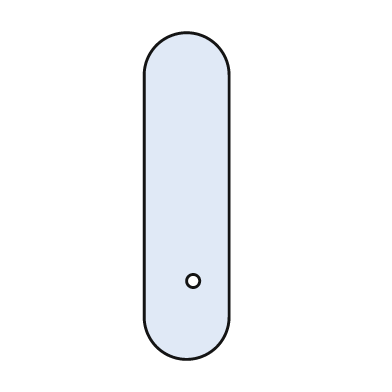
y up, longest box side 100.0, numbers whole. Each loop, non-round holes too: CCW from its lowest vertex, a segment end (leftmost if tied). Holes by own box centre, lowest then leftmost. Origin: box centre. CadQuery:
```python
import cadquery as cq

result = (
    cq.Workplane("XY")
    .moveTo(-13.0, -37.0)
    .threePointArc((0.0, -50.0), (13.0, -37.0))
    .lineTo(13.0, 37.0)
    .threePointArc((0.0, 50.0), (-13.0, 37.0))
    .close()
    .moveTo(2.0, -26.0)
    .circle(2.0)
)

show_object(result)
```